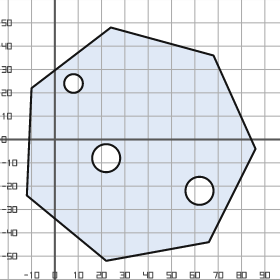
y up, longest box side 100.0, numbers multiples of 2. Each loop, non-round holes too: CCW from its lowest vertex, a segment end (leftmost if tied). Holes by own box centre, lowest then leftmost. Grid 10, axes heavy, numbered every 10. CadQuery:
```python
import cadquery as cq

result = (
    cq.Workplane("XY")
    .moveTo(22.0, -52.0)
    .lineTo(66.0, -44.0)
    .lineTo(86.0, -4.0)
    .lineTo(68.0, 36.0)
    .lineTo(24.0, 48.0)
    .lineTo(-10.0, 22.0)
    .lineTo(-12.0, -24.0)
    .close()
    .moveTo(62.0, -22.0)
    .circle(6.0)
    .moveTo(22.0, -8.0)
    .circle(6.0)
    .moveTo(8.0, 24.0)
    .circle(4.0)
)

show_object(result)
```